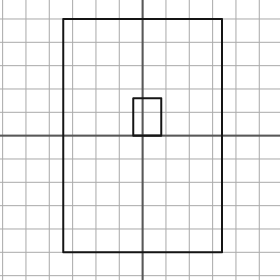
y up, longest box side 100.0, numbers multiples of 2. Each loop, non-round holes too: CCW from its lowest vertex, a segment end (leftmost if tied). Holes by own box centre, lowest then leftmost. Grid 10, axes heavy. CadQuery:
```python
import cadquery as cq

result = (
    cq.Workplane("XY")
    .moveTo(-34.0, -50.0)
    .lineTo(34.0, -50.0)
    .lineTo(34.0, 50.0)
    .lineTo(-34.0, 50.0)
    .close()
    .moveTo(-4.0, 0.0)
    .lineTo(8.0, 0.0)
    .lineTo(8.0, 16.0)
    .lineTo(-4.0, 16.0)
    .close()
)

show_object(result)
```